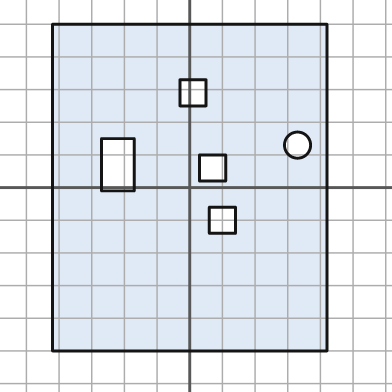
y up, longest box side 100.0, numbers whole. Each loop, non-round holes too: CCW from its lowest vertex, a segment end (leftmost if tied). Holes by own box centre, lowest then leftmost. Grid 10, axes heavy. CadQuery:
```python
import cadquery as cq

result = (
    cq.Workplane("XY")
    .moveTo(-42.0, -50.0)
    .lineTo(42.0, -50.0)
    .lineTo(42.0, 50.0)
    .lineTo(-42.0, 50.0)
    .close()
    .moveTo(6.0, -14.0)
    .lineTo(14.0, -14.0)
    .lineTo(14.0, -6.0)
    .lineTo(6.0, -6.0)
    .close()
    .moveTo(3.0, 2.0)
    .lineTo(11.0, 2.0)
    .lineTo(11.0, 10.0)
    .lineTo(3.0, 10.0)
    .close()
    .moveTo(-27.0, -1.0)
    .lineTo(-17.0, -1.0)
    .lineTo(-17.0, 15.0)
    .lineTo(-27.0, 15.0)
    .close()
    .moveTo(33.0, 13.0)
    .circle(4.0)
    .moveTo(-3.0, 25.0)
    .lineTo(5.0, 25.0)
    .lineTo(5.0, 33.0)
    .lineTo(-3.0, 33.0)
    .close()
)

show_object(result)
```